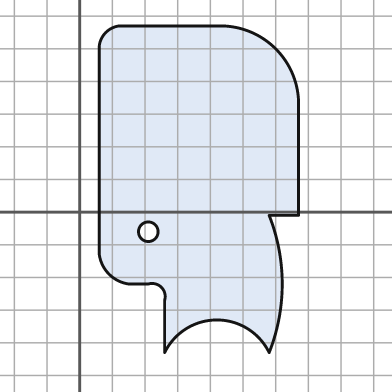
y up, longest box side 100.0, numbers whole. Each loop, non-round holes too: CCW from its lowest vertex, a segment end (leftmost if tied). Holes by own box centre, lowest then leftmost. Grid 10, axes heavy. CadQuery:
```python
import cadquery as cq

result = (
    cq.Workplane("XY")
    .moveTo(26.0, -43.0)
    .threePointArc((42.0, -33.0), (58.0, -43.0))
    .threePointArc((62.0, -22.0), (58.0, -1.0))
    .lineTo(67.0, -1.0)
    .lineTo(67.0, 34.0)
    .threePointArc((60.0, 50.0), (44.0, 57.0))
    .lineTo(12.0, 57.0)
    .threePointArc((8.0, 55.0), (6.0, 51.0))
    .lineTo(6.0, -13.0)
    .threePointArc((9.0, -19.0), (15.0, -22.0))
    .lineTo(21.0, -22.0)
    .threePointArc((25.0, -23.0), (26.0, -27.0))
    .close()
    .moveTo(21.0, -6.0)
    .circle(3.0)
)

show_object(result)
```